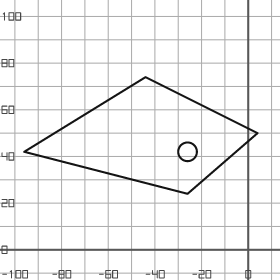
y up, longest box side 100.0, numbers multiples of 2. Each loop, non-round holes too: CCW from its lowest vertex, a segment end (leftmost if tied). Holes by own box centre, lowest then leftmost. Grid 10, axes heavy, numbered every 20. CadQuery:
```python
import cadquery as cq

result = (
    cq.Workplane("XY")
    .moveTo(-26.0, 24.0)
    .lineTo(4.0, 50.0)
    .lineTo(-44.0, 74.0)
    .lineTo(-96.0, 42.0)
    .close()
    .moveTo(-26.0, 42.0)
    .circle(4.0)
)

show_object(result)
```